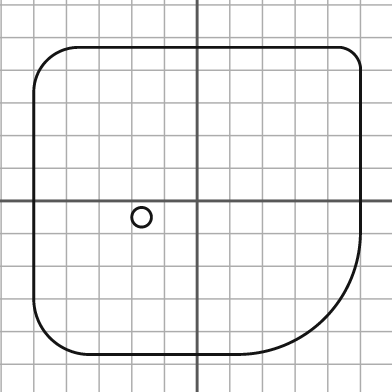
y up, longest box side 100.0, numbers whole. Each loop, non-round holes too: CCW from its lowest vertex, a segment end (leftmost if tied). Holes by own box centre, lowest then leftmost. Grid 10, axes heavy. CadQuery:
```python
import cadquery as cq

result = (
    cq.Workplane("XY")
    .moveTo(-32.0, -47.0)
    .lineTo(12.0, -47.0)
    .threePointArc((39.0, -36.0), (50.0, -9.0))
    .lineTo(50.0, 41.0)
    .threePointArc((48.0, 45.0), (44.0, 47.0))
    .lineTo(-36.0, 47.0)
    .threePointArc((-46.0, 43.0), (-50.0, 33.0))
    .lineTo(-50.0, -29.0)
    .threePointArc((-45.0, -42.0), (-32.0, -47.0))
    .close()
    .moveTo(-17.0, -5.0)
    .circle(3.0)
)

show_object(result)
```